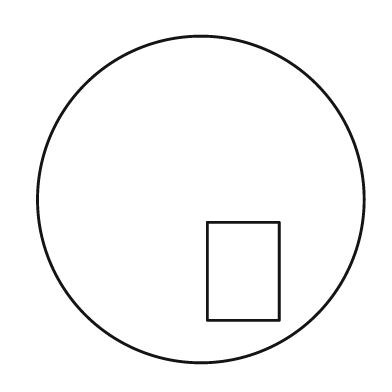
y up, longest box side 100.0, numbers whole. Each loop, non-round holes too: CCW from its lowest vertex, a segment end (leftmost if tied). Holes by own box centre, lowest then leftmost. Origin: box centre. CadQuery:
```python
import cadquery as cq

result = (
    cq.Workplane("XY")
    .moveTo(0.0, 0.0)
    .circle(50.0)
    .moveTo(2.0, -37.0)
    .lineTo(24.0, -37.0)
    .lineTo(24.0, -7.0)
    .lineTo(2.0, -7.0)
    .close()
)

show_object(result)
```